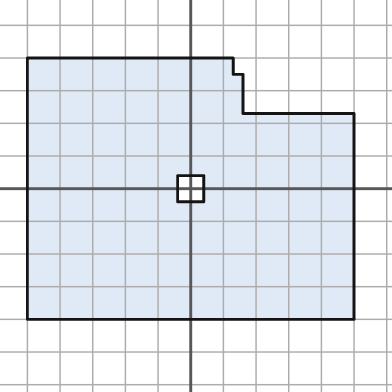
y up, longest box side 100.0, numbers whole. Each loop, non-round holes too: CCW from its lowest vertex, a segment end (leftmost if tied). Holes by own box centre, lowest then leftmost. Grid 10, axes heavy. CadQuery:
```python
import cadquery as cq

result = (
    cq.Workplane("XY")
    .moveTo(-50.0, -40.0)
    .lineTo(50.0, -40.0)
    .lineTo(50.0, 23.0)
    .lineTo(16.0, 23.0)
    .lineTo(16.0, 35.0)
    .lineTo(13.0, 35.0)
    .lineTo(13.0, 40.0)
    .lineTo(-50.0, 40.0)
    .close()
    .moveTo(-4.0, -4.0)
    .lineTo(4.0, -4.0)
    .lineTo(4.0, 4.0)
    .lineTo(-4.0, 4.0)
    .close()
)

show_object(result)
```